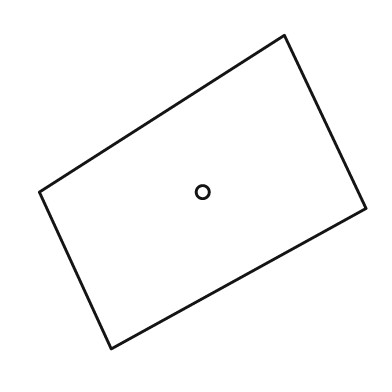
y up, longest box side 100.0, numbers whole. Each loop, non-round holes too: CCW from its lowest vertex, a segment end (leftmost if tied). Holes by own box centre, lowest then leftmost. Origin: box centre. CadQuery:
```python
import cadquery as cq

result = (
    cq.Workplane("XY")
    .moveTo(-28.0, -48.0)
    .lineTo(50.0, -5.0)
    .lineTo(25.0, 48.0)
    .lineTo(-50.0, 0.0)
    .close()
    .moveTo(0.0, 0.0)
    .circle(2.0)
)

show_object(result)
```